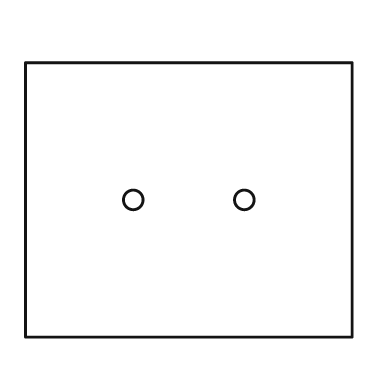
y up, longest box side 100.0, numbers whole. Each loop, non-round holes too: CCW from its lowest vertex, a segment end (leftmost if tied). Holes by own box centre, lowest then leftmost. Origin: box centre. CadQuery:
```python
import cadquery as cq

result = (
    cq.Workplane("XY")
    .moveTo(-50.0, -42.0)
    .lineTo(50.0, -42.0)
    .lineTo(50.0, 42.0)
    .lineTo(-50.0, 42.0)
    .close()
    .moveTo(-17.0, 0.0)
    .circle(3.0)
    .moveTo(17.0, 0.0)
    .circle(3.0)
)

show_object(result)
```